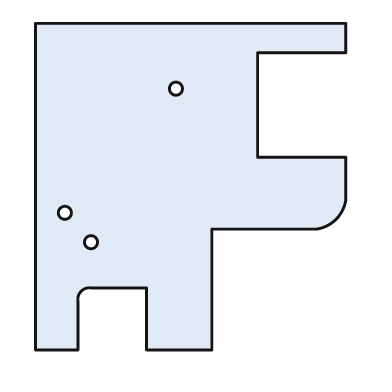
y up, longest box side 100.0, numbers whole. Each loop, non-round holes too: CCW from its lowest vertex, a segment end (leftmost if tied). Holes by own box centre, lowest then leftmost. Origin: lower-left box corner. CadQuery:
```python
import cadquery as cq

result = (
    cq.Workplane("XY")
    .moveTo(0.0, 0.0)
    .lineTo(13.0, 0.0)
    .lineTo(13.0, 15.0)
    .threePointArc((14.0, 18.0), (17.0, 19.0))
    .lineTo(34.0, 19.0)
    .lineTo(34.0, 0.0)
    .lineTo(54.0, 0.0)
    .lineTo(54.0, 37.0)
    .lineTo(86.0, 37.0)
    .threePointArc((92.0, 40.0), (95.0, 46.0))
    .lineTo(95.0, 59.0)
    .lineTo(68.0, 59.0)
    .lineTo(68.0, 91.0)
    .lineTo(95.0, 91.0)
    .lineTo(95.0, 100.0)
    .lineTo(0.0, 100.0)
    .close()
    .moveTo(17.0, 33.0)
    .circle(2.0)
    .moveTo(9.0, 42.0)
    .circle(2.0)
    .moveTo(43.0, 80.0)
    .circle(2.0)
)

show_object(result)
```